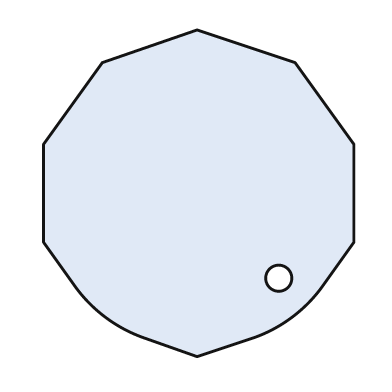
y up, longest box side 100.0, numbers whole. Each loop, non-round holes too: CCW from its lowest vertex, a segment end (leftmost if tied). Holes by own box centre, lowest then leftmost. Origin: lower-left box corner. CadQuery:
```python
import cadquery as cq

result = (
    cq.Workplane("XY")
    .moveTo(47.0, 0.0)
    .lineTo(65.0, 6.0)
    .threePointArc((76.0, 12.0), (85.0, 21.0))
    .lineTo(95.0, 35.0)
    .lineTo(95.0, 65.0)
    .lineTo(77.0, 90.0)
    .lineTo(47.0, 100.0)
    .lineTo(18.0, 90.0)
    .lineTo(0.0, 65.0)
    .lineTo(0.0, 35.0)
    .lineTo(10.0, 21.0)
    .threePointArc((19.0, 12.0), (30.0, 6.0))
    .close()
    .moveTo(72.0, 24.0)
    .circle(4.0)
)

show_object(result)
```